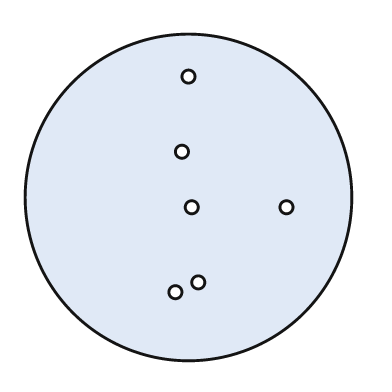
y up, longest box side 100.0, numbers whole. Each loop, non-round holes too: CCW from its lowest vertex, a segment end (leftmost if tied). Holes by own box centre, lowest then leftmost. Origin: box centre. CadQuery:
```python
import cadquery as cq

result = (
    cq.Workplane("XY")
    .moveTo(0.0, 0.0)
    .circle(50.0)
    .moveTo(-4.0, -29.0)
    .circle(2.0)
    .moveTo(3.0, -26.0)
    .circle(2.0)
    .moveTo(1.0, -3.0)
    .circle(2.0)
    .moveTo(30.0, -3.0)
    .circle(2.0)
    .moveTo(-2.0, 14.0)
    .circle(2.0)
    .moveTo(0.0, 37.0)
    .circle(2.0)
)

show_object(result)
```